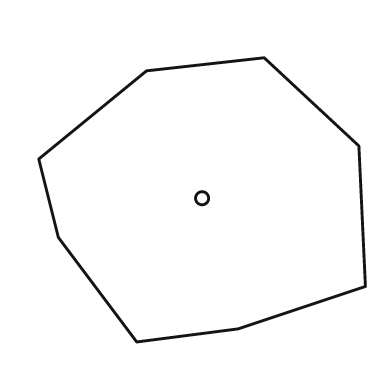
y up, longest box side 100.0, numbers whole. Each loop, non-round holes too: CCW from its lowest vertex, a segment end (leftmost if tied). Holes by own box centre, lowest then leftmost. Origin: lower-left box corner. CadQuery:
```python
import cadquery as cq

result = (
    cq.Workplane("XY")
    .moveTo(30.0, 0.0)
    .lineTo(61.0, 4.0)
    .lineTo(100.0, 17.0)
    .lineTo(98.0, 60.0)
    .lineTo(69.0, 87.0)
    .lineTo(33.0, 83.0)
    .lineTo(0.0, 56.0)
    .lineTo(6.0, 32.0)
    .close()
    .moveTo(50.0, 44.0)
    .circle(2.0)
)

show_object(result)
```